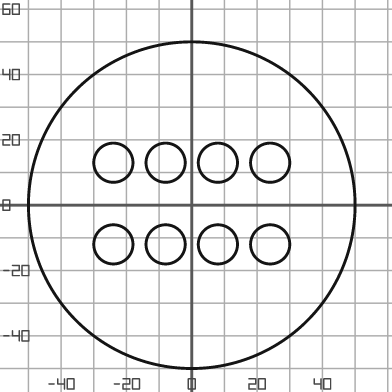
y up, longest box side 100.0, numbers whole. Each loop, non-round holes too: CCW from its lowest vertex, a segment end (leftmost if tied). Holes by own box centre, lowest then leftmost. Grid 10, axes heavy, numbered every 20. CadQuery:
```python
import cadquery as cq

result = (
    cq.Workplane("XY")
    .moveTo(0.0, 0.0)
    .circle(50.0)
    .moveTo(-24.0, -12.0)
    .circle(6.0)
    .moveTo(-8.0, -12.0)
    .circle(6.0)
    .moveTo(8.0, -12.0)
    .circle(6.0)
    .moveTo(24.0, -12.0)
    .circle(6.0)
    .moveTo(-24.0, 13.0)
    .circle(6.0)
    .moveTo(-8.0, 13.0)
    .circle(6.0)
    .moveTo(8.0, 13.0)
    .circle(6.0)
    .moveTo(24.0, 13.0)
    .circle(6.0)
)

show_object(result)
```